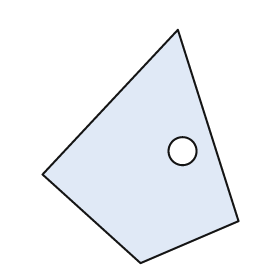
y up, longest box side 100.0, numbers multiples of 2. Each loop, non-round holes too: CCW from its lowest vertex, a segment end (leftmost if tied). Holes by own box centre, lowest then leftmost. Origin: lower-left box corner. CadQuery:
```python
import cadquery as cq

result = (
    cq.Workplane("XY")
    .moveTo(42.0, 0.0)
    .lineTo(84.0, 18.0)
    .lineTo(58.0, 100.0)
    .lineTo(0.0, 38.0)
    .close()
    .moveTo(60.0, 48.0)
    .circle(6.0)
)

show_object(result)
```